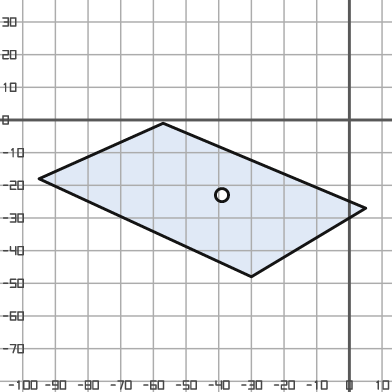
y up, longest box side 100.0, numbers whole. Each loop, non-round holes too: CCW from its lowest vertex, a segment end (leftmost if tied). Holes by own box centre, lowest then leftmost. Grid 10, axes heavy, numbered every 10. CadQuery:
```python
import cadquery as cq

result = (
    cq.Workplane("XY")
    .moveTo(-30.0, -48.0)
    .lineTo(5.0, -27.0)
    .lineTo(-57.0, -1.0)
    .lineTo(-95.0, -18.0)
    .close()
    .moveTo(-39.0, -23.0)
    .circle(2.0)
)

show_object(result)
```